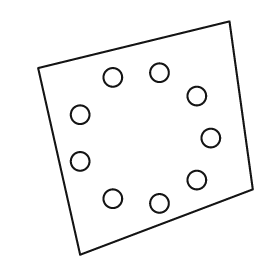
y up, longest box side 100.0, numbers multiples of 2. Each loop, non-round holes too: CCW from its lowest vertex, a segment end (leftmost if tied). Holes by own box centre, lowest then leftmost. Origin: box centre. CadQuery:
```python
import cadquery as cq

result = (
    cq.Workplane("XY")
    .moveTo(-28.0, -50.0)
    .lineTo(46.0, -22.0)
    .lineTo(36.0, 50.0)
    .lineTo(-46.0, 30.0)
    .close()
    .moveTo(6.0, -28.0)
    .circle(4.0)
    .moveTo(-14.0, -26.0)
    .circle(4.0)
    .moveTo(22.0, -18.0)
    .circle(4.0)
    .moveTo(-28.0, -10.0)
    .circle(4.0)
    .moveTo(28.0, 0.0)
    .circle(4.0)
    .moveTo(-28.0, 10.0)
    .circle(4.0)
    .moveTo(22.0, 18.0)
    .circle(4.0)
    .moveTo(-14.0, 26.0)
    .circle(4.0)
    .moveTo(6.0, 28.0)
    .circle(4.0)
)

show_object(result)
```